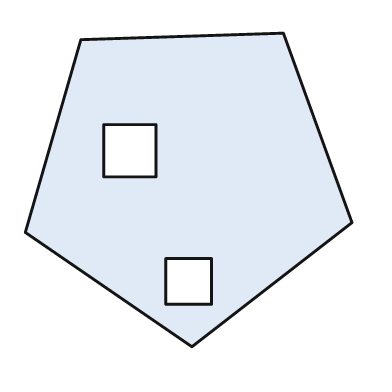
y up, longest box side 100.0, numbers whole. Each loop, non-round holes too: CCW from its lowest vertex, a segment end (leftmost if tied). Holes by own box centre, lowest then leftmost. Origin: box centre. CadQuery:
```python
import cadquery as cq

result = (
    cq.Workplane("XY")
    .moveTo(1.0, -48.0)
    .lineTo(50.0, -10.0)
    .lineTo(29.0, 48.0)
    .lineTo(-33.0, 46.0)
    .lineTo(-50.0, -13.0)
    .close()
    .moveTo(-7.0, -35.0)
    .lineTo(7.0, -35.0)
    .lineTo(7.0, -21.0)
    .lineTo(-7.0, -21.0)
    .close()
    .moveTo(-26.0, 4.0)
    .lineTo(-10.0, 4.0)
    .lineTo(-10.0, 20.0)
    .lineTo(-26.0, 20.0)
    .close()
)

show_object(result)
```